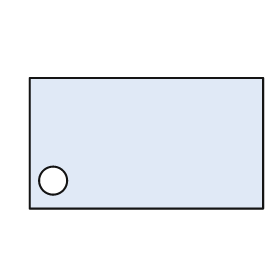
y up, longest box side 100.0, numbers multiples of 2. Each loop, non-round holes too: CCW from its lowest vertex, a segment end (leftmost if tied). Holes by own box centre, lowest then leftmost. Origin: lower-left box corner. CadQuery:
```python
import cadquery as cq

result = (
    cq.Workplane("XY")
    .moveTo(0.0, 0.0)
    .lineTo(100.0, 0.0)
    .lineTo(100.0, 56.0)
    .lineTo(0.0, 56.0)
    .close()
    .moveTo(10.0, 12.0)
    .circle(6.0)
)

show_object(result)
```